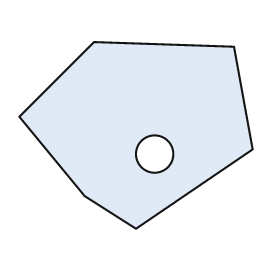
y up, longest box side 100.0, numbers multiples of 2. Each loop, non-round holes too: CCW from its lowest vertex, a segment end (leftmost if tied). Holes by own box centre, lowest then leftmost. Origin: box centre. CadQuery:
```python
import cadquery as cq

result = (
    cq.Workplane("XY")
    .moveTo(0.0, -40.0)
    .lineTo(50.0, -6.0)
    .lineTo(42.0, 38.0)
    .lineTo(-18.0, 40.0)
    .lineTo(-50.0, 8.0)
    .lineTo(-22.0, -26.0)
    .close()
    .moveTo(8.0, -8.0)
    .circle(8.0)
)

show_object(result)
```